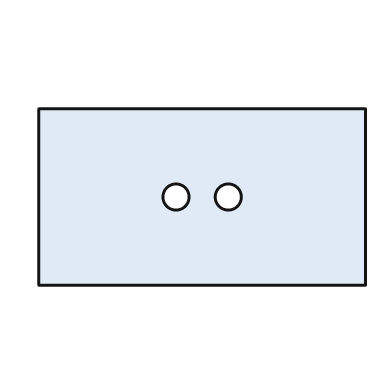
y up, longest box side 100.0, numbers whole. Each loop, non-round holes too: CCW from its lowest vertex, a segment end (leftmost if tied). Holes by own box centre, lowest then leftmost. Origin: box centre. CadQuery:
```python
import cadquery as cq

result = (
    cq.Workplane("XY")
    .moveTo(-50.0, -27.0)
    .lineTo(50.0, -27.0)
    .lineTo(50.0, 27.0)
    .lineTo(-50.0, 27.0)
    .close()
    .moveTo(-8.0, 0.0)
    .circle(4.0)
    .moveTo(8.0, 0.0)
    .circle(4.0)
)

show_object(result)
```